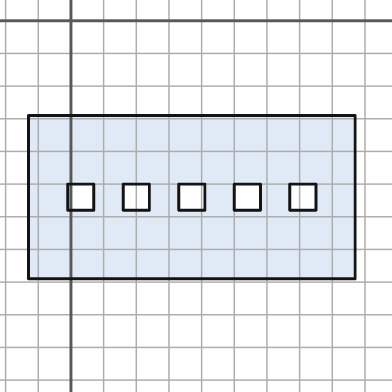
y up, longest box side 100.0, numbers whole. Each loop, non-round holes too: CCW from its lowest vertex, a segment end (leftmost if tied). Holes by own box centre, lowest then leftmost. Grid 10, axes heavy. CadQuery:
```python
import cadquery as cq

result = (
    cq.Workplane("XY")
    .moveTo(-13.0, -79.0)
    .lineTo(87.0, -79.0)
    .lineTo(87.0, -29.0)
    .lineTo(-13.0, -29.0)
    .close()
    .moveTo(-1.0, -58.0)
    .lineTo(7.0, -58.0)
    .lineTo(7.0, -50.0)
    .lineTo(-1.0, -50.0)
    .close()
    .moveTo(16.0, -58.0)
    .lineTo(24.0, -58.0)
    .lineTo(24.0, -50.0)
    .lineTo(16.0, -50.0)
    .close()
    .moveTo(33.0, -58.0)
    .lineTo(41.0, -58.0)
    .lineTo(41.0, -50.0)
    .lineTo(33.0, -50.0)
    .close()
    .moveTo(50.0, -58.0)
    .lineTo(58.0, -58.0)
    .lineTo(58.0, -50.0)
    .lineTo(50.0, -50.0)
    .close()
    .moveTo(67.0, -58.0)
    .lineTo(75.0, -58.0)
    .lineTo(75.0, -50.0)
    .lineTo(67.0, -50.0)
    .close()
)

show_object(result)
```